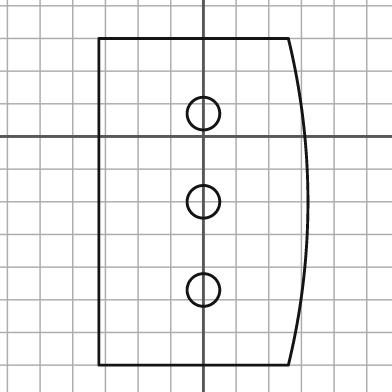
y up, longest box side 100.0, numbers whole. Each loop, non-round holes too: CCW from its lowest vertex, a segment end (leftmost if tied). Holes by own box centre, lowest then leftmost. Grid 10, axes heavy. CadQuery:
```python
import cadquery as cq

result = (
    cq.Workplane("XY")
    .moveTo(-32.0, -70.0)
    .lineTo(26.0, -70.0)
    .threePointArc((32.0, -20.0), (26.0, 30.0))
    .lineTo(-32.0, 30.0)
    .close()
    .moveTo(0.0, -47.0)
    .circle(5.0)
    .moveTo(0.0, -20.0)
    .circle(5.0)
    .moveTo(0.0, 7.0)
    .circle(5.0)
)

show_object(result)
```